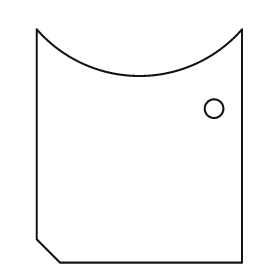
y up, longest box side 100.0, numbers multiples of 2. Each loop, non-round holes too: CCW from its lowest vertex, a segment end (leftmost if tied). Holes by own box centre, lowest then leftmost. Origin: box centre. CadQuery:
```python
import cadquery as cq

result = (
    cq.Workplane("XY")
    .moveTo(-34.0, -50.0)
    .lineTo(44.0, -50.0)
    .lineTo(44.0, 50.0)
    .threePointArc((0.0, 30.0), (-44.0, 50.0))
    .lineTo(-44.0, -40.0)
    .close()
    .moveTo(32.0, 16.0)
    .circle(4.0)
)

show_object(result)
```